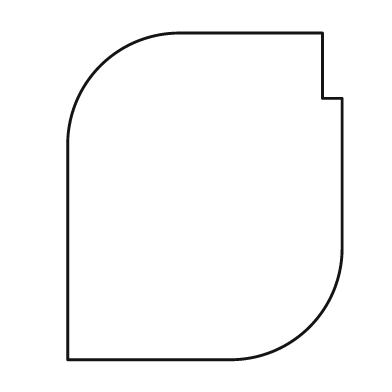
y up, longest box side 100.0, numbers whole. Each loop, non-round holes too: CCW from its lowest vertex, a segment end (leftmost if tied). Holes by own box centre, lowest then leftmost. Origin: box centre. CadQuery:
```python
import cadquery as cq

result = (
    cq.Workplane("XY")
    .moveTo(-42.0, -50.0)
    .lineTo(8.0, -50.0)
    .threePointArc((32.0, -40.0), (42.0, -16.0))
    .lineTo(42.0, 30.0)
    .lineTo(36.0, 30.0)
    .lineTo(36.0, 50.0)
    .lineTo(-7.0, 50.0)
    .threePointArc((-32.0, 40.0), (-42.0, 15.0))
    .close()
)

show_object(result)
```